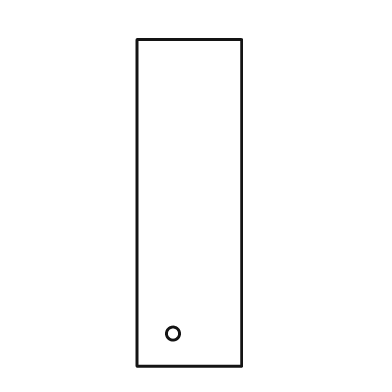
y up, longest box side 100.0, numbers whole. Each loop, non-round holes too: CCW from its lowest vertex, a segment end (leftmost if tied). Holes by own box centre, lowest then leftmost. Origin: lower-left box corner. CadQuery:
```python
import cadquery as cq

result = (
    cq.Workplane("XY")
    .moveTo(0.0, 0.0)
    .lineTo(32.0, 0.0)
    .lineTo(32.0, 100.0)
    .lineTo(0.0, 100.0)
    .close()
    .moveTo(11.0, 10.0)
    .circle(2.0)
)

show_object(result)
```